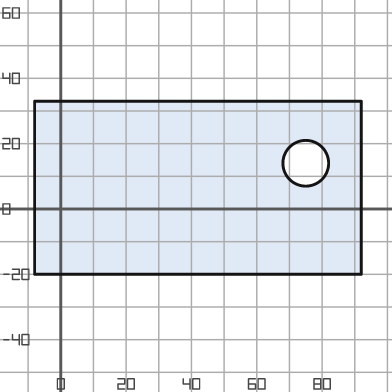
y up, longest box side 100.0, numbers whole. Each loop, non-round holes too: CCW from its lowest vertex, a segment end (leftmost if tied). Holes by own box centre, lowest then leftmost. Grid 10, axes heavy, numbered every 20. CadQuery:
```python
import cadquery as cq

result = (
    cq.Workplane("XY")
    .moveTo(-8.0, -20.0)
    .lineTo(92.0, -20.0)
    .lineTo(92.0, 33.0)
    .lineTo(-8.0, 33.0)
    .close()
    .moveTo(75.0, 14.0)
    .circle(7.0)
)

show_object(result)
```